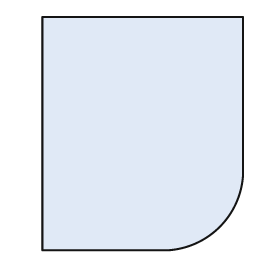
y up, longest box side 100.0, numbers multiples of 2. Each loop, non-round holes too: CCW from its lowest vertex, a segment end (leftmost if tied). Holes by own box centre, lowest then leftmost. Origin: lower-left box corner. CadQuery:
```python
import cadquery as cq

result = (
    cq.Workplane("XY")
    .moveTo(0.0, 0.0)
    .lineTo(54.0, 0.0)
    .threePointArc((76.0, 10.0), (86.0, 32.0))
    .lineTo(86.0, 100.0)
    .lineTo(0.0, 100.0)
    .close()
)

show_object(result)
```